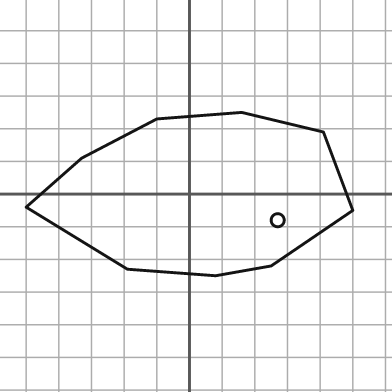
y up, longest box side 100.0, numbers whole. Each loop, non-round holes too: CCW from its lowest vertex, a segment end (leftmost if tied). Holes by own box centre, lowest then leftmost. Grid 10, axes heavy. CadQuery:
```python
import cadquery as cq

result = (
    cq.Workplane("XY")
    .moveTo(8.0, -25.0)
    .lineTo(25.0, -22.0)
    .lineTo(50.0, -5.0)
    .lineTo(41.0, 19.0)
    .lineTo(16.0, 25.0)
    .lineTo(-10.0, 23.0)
    .lineTo(-33.0, 11.0)
    .lineTo(-50.0, -4.0)
    .lineTo(-19.0, -23.0)
    .close()
    .moveTo(27.0, -8.0)
    .circle(2.0)
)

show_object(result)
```